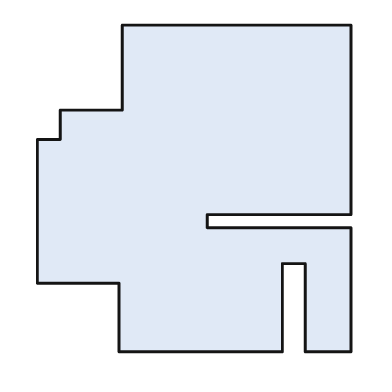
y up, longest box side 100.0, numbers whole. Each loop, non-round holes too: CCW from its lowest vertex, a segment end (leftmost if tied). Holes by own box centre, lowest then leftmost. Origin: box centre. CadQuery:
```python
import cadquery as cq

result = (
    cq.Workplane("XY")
    .moveTo(-23.0, -50.0)
    .lineTo(27.0, -50.0)
    .lineTo(27.0, -23.0)
    .lineTo(34.0, -23.0)
    .lineTo(34.0, -50.0)
    .lineTo(48.0, -50.0)
    .lineTo(48.0, -12.0)
    .lineTo(4.0, -12.0)
    .lineTo(4.0, -8.0)
    .lineTo(48.0, -8.0)
    .lineTo(48.0, 50.0)
    .lineTo(-22.0, 50.0)
    .lineTo(-22.0, 24.0)
    .lineTo(-41.0, 24.0)
    .lineTo(-41.0, 15.0)
    .lineTo(-48.0, 15.0)
    .lineTo(-48.0, -29.0)
    .lineTo(-23.0, -29.0)
    .close()
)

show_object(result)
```